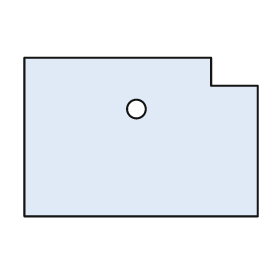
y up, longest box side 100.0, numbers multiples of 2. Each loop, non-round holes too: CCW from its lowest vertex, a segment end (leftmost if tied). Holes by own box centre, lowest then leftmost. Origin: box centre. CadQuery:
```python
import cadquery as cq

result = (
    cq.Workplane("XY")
    .moveTo(-50.0, -34.0)
    .lineTo(50.0, -34.0)
    .lineTo(50.0, 22.0)
    .lineTo(30.0, 22.0)
    .lineTo(30.0, 34.0)
    .lineTo(-50.0, 34.0)
    .close()
    .moveTo(-2.0, 12.0)
    .circle(4.0)
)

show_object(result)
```